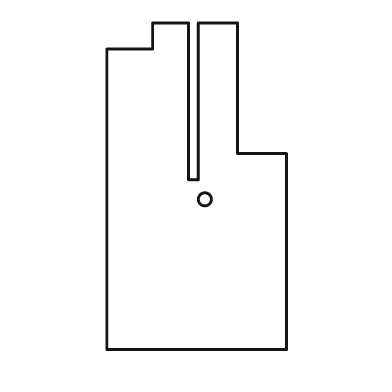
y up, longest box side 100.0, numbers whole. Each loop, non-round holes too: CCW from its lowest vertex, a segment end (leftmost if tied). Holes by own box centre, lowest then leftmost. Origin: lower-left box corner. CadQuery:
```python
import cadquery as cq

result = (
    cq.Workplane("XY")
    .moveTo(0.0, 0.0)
    .lineTo(55.0, 0.0)
    .lineTo(55.0, 60.0)
    .lineTo(40.0, 60.0)
    .lineTo(40.0, 100.0)
    .lineTo(28.0, 100.0)
    .lineTo(28.0, 52.0)
    .lineTo(25.0, 52.0)
    .lineTo(25.0, 100.0)
    .lineTo(14.0, 100.0)
    .lineTo(14.0, 92.0)
    .lineTo(0.0, 92.0)
    .close()
    .moveTo(30.0, 46.0)
    .circle(2.0)
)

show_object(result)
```